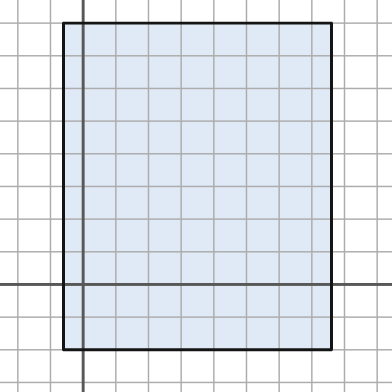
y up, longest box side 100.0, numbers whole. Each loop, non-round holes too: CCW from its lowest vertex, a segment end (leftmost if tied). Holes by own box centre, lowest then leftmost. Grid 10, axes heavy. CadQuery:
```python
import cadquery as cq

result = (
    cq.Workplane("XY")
    .moveTo(-6.0, -20.0)
    .lineTo(76.0, -20.0)
    .lineTo(76.0, 80.0)
    .lineTo(-6.0, 80.0)
    .close()
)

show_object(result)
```